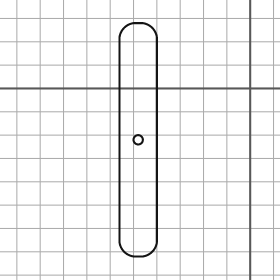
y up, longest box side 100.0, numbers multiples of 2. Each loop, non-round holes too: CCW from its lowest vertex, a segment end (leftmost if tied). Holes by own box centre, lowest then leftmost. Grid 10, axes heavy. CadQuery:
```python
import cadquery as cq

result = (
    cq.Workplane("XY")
    .moveTo(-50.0, -72.0)
    .lineTo(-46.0, -72.0)
    .threePointArc((-42.0, -70.0), (-40.0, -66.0))
    .lineTo(-40.0, 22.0)
    .threePointArc((-42.0, 26.0), (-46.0, 28.0))
    .lineTo(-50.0, 28.0)
    .threePointArc((-54.0, 26.0), (-56.0, 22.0))
    .lineTo(-56.0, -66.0)
    .threePointArc((-54.0, -70.0), (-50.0, -72.0))
    .close()
    .moveTo(-48.0, -22.0)
    .circle(2.0)
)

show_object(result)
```